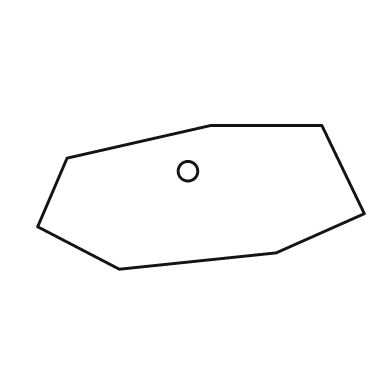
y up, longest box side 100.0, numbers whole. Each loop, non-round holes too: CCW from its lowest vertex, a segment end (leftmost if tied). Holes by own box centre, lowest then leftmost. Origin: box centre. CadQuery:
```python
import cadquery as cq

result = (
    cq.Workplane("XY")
    .moveTo(-25.0, -22.0)
    .lineTo(23.0, -17.0)
    .lineTo(50.0, -5.0)
    .lineTo(37.0, 22.0)
    .lineTo(3.0, 22.0)
    .lineTo(-41.0, 12.0)
    .lineTo(-50.0, -9.0)
    .close()
    .moveTo(-4.0, 8.0)
    .circle(3.0)
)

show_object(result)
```